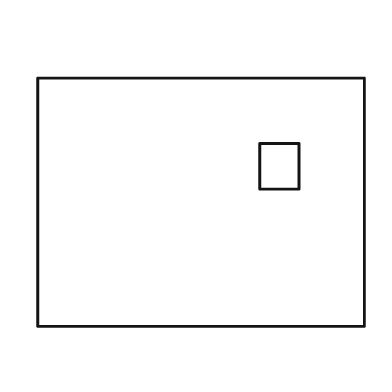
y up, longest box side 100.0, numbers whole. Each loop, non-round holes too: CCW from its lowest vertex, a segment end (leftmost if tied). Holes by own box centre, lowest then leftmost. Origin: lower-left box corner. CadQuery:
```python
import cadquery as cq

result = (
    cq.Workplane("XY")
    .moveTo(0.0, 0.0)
    .lineTo(100.0, 0.0)
    .lineTo(100.0, 76.0)
    .lineTo(0.0, 76.0)
    .close()
    .moveTo(68.0, 42.0)
    .lineTo(80.0, 42.0)
    .lineTo(80.0, 56.0)
    .lineTo(68.0, 56.0)
    .close()
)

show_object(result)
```